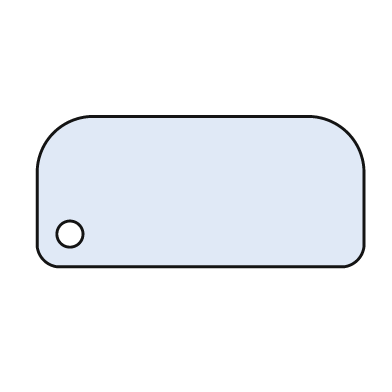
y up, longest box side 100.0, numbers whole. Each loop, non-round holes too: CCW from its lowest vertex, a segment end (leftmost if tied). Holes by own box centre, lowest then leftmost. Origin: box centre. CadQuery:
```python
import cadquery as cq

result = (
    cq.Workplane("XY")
    .moveTo(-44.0, -23.0)
    .lineTo(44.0, -23.0)
    .threePointArc((48.0, -21.0), (50.0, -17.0))
    .lineTo(50.0, 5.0)
    .threePointArc((45.0, 18.0), (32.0, 23.0))
    .lineTo(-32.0, 23.0)
    .threePointArc((-45.0, 18.0), (-50.0, 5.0))
    .lineTo(-50.0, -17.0)
    .threePointArc((-48.0, -21.0), (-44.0, -23.0))
    .close()
    .moveTo(-40.0, -13.0)
    .circle(4.0)
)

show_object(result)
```